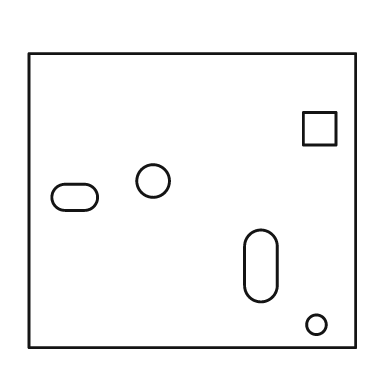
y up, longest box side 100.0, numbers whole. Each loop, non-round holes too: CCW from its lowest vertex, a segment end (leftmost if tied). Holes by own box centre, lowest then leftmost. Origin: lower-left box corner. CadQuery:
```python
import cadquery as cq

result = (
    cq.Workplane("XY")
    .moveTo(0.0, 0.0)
    .lineTo(100.0, 0.0)
    .lineTo(100.0, 90.0)
    .lineTo(0.0, 90.0)
    .close()
    .moveTo(88.0, 7.0)
    .circle(3.0)
    .moveTo(66.0, 19.0)
    .threePointArc((71.0, 14.0), (76.0, 19.0))
    .lineTo(76.0, 31.0)
    .threePointArc((71.0, 36.0), (66.0, 31.0))
    .close()
    .moveTo(11.0, 42.0)
    .lineTo(17.0, 42.0)
    .threePointArc((21.0, 46.0), (17.0, 50.0))
    .lineTo(11.0, 50.0)
    .threePointArc((7.0, 46.0), (11.0, 42.0))
    .close()
    .moveTo(38.0, 51.0)
    .circle(5.0)
    .moveTo(84.0, 62.0)
    .lineTo(94.0, 62.0)
    .lineTo(94.0, 72.0)
    .lineTo(84.0, 72.0)
    .close()
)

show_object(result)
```